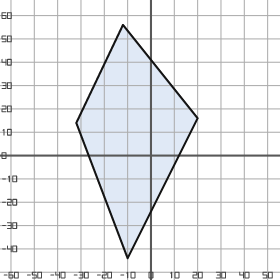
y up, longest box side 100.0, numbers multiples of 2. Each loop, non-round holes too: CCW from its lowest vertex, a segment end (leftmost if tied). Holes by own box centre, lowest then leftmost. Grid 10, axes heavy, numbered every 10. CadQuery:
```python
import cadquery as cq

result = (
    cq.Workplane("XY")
    .moveTo(-10.0, -44.0)
    .lineTo(20.0, 16.0)
    .lineTo(-12.0, 56.0)
    .lineTo(-32.0, 14.0)
    .close()
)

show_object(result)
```